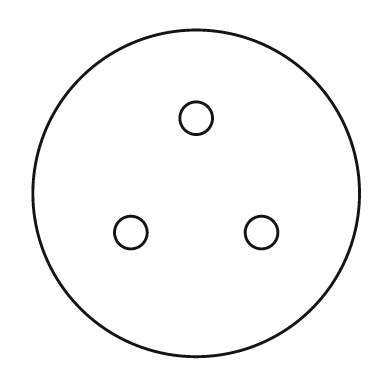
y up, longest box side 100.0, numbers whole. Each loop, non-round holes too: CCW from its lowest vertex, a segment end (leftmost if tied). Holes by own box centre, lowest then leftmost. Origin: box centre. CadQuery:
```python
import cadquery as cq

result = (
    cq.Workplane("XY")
    .moveTo(0.0, 0.0)
    .circle(50.0)
    .moveTo(-20.0, -12.0)
    .circle(5.0)
    .moveTo(20.0, -12.0)
    .circle(5.0)
    .moveTo(0.0, 23.0)
    .circle(5.0)
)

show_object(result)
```